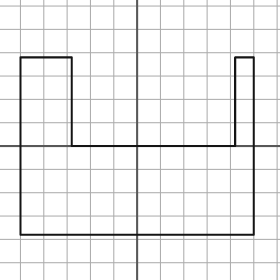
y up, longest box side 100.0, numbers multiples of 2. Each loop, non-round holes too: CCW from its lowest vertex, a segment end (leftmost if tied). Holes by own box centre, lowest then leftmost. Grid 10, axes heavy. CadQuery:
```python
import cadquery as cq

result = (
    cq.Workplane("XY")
    .moveTo(-50.0, -38.0)
    .lineTo(50.0, -38.0)
    .lineTo(50.0, 38.0)
    .lineTo(42.0, 38.0)
    .lineTo(42.0, 0.0)
    .lineTo(-28.0, 0.0)
    .lineTo(-28.0, 38.0)
    .lineTo(-50.0, 38.0)
    .close()
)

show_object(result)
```